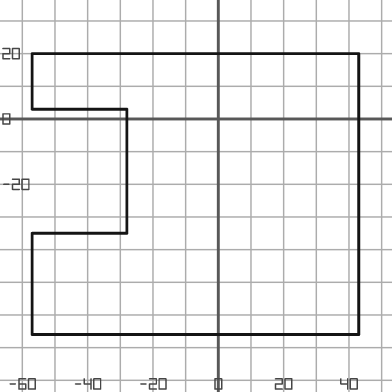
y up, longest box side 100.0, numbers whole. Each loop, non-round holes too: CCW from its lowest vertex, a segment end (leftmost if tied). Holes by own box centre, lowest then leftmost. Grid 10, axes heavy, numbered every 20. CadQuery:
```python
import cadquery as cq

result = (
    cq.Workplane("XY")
    .moveTo(-57.0, -66.0)
    .lineTo(43.0, -66.0)
    .lineTo(43.0, 20.0)
    .lineTo(-57.0, 20.0)
    .lineTo(-57.0, 3.0)
    .lineTo(-28.0, 3.0)
    .lineTo(-28.0, -35.0)
    .lineTo(-57.0, -35.0)
    .close()
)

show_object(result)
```